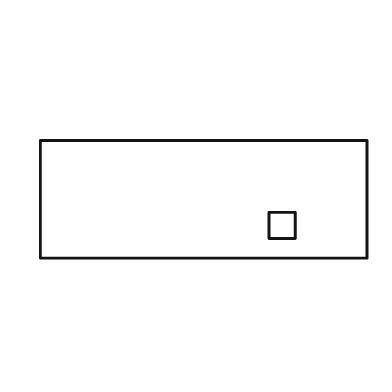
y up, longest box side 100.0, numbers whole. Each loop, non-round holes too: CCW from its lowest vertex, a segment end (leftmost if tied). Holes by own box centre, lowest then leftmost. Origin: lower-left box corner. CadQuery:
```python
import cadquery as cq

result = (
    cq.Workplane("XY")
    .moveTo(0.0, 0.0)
    .lineTo(100.0, 0.0)
    .lineTo(100.0, 36.0)
    .lineTo(0.0, 36.0)
    .close()
    .moveTo(70.0, 6.0)
    .lineTo(78.0, 6.0)
    .lineTo(78.0, 14.0)
    .lineTo(70.0, 14.0)
    .close()
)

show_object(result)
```